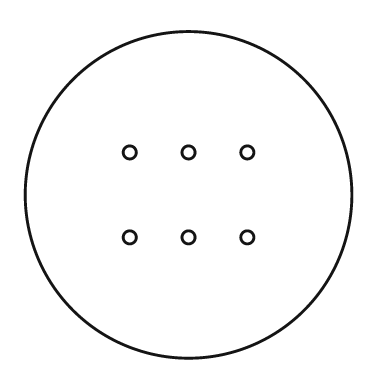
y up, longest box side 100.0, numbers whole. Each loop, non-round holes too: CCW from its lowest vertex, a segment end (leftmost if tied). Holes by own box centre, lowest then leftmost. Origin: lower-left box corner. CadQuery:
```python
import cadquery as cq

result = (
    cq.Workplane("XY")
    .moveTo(50.0, 50.0)
    .circle(50.0)
    .moveTo(32.0, 37.0)
    .circle(2.0)
    .moveTo(50.0, 37.0)
    .circle(2.0)
    .moveTo(68.0, 37.0)
    .circle(2.0)
    .moveTo(32.0, 63.0)
    .circle(2.0)
    .moveTo(50.0, 63.0)
    .circle(2.0)
    .moveTo(68.0, 63.0)
    .circle(2.0)
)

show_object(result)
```